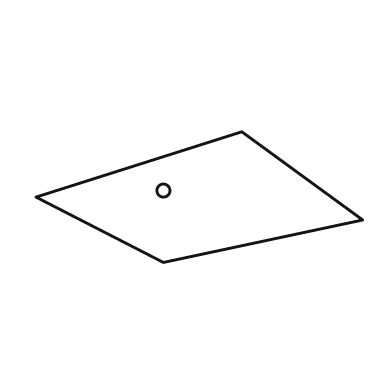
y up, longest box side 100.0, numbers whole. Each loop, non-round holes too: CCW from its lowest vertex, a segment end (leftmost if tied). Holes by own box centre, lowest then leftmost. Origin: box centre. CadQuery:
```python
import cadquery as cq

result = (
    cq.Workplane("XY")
    .moveTo(-11.0, -20.0)
    .lineTo(50.0, -7.0)
    .lineTo(13.0, 20.0)
    .lineTo(-50.0, 0.0)
    .close()
    .moveTo(-11.0, 2.0)
    .circle(2.0)
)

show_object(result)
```